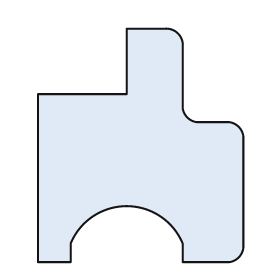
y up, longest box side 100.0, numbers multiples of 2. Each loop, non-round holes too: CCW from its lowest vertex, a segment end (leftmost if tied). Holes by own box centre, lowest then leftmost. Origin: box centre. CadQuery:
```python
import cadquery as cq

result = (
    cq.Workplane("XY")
    .moveTo(-44.0, -50.0)
    .lineTo(-30.0, -50.0)
    .lineTo(-30.0, -42.0)
    .threePointArc((-6.0, -26.0), (18.0, -42.0))
    .lineTo(18.0, -50.0)
    .lineTo(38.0, -50.0)
    .threePointArc((42.0, -48.0), (44.0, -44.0))
    .lineTo(44.0, 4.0)
    .threePointArc((42.0, 8.0), (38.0, 10.0))
    .lineTo(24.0, 10.0)
    .threePointArc((20.0, 12.0), (18.0, 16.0))
    .lineTo(18.0, 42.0)
    .threePointArc((16.0, 48.0), (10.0, 50.0))
    .lineTo(-6.0, 50.0)
    .lineTo(-6.0, 22.0)
    .lineTo(-44.0, 22.0)
    .close()
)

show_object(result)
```